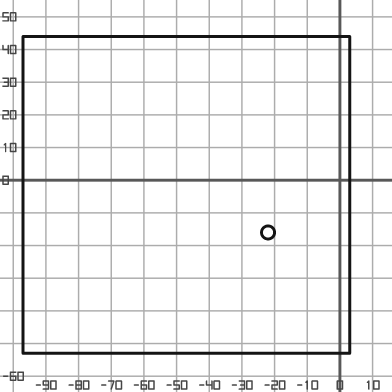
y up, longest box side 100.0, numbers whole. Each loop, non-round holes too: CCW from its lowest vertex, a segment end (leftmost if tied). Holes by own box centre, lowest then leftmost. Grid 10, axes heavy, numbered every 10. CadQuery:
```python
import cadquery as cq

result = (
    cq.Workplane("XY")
    .moveTo(-97.0, -53.0)
    .lineTo(3.0, -53.0)
    .lineTo(3.0, 44.0)
    .lineTo(-97.0, 44.0)
    .close()
    .moveTo(-22.0, -16.0)
    .circle(2.0)
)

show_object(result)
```